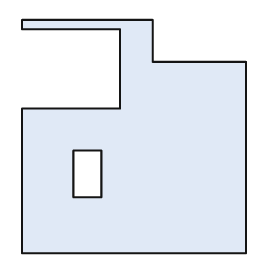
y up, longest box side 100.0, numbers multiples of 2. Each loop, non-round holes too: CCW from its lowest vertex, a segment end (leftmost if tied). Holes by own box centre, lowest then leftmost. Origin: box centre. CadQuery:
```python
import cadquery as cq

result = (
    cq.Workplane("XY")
    .moveTo(-48.0, -50.0)
    .lineTo(48.0, -50.0)
    .lineTo(48.0, 32.0)
    .lineTo(8.0, 32.0)
    .lineTo(8.0, 50.0)
    .lineTo(-48.0, 50.0)
    .lineTo(-48.0, 46.0)
    .lineTo(-6.0, 46.0)
    .lineTo(-6.0, 12.0)
    .lineTo(-48.0, 12.0)
    .close()
    .moveTo(-26.0, -26.0)
    .lineTo(-14.0, -26.0)
    .lineTo(-14.0, -6.0)
    .lineTo(-26.0, -6.0)
    .close()
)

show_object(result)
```